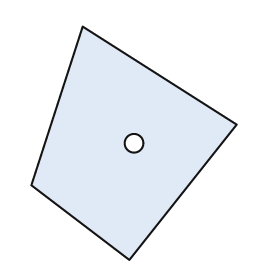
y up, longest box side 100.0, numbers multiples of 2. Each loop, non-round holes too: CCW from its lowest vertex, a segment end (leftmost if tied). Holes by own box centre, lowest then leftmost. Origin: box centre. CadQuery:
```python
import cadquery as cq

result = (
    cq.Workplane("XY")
    .moveTo(-2.0, -50.0)
    .lineTo(44.0, 8.0)
    .lineTo(-22.0, 50.0)
    .lineTo(-44.0, -18.0)
    .close()
    .moveTo(0.0, 0.0)
    .circle(4.0)
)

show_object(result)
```